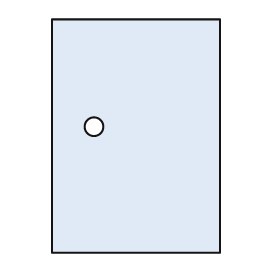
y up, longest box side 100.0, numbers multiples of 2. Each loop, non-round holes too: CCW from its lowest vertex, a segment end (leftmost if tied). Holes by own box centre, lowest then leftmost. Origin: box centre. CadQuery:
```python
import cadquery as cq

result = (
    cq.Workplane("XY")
    .moveTo(-36.0, -50.0)
    .lineTo(36.0, -50.0)
    .lineTo(36.0, 50.0)
    .lineTo(-36.0, 50.0)
    .close()
    .moveTo(-18.0, 4.0)
    .circle(4.0)
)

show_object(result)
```